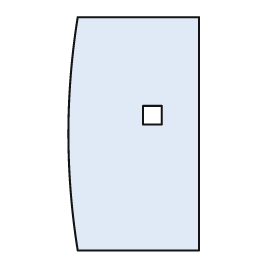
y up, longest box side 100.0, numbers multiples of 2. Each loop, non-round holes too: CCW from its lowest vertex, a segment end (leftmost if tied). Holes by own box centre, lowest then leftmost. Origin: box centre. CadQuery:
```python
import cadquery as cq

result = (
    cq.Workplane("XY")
    .moveTo(-24.0, -50.0)
    .lineTo(28.0, -50.0)
    .lineTo(28.0, 50.0)
    .lineTo(-24.0, 50.0)
    .threePointArc((-28.0, 0.0), (-24.0, -50.0))
    .close()
    .moveTo(4.0, 4.0)
    .lineTo(12.0, 4.0)
    .lineTo(12.0, 12.0)
    .lineTo(4.0, 12.0)
    .close()
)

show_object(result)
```